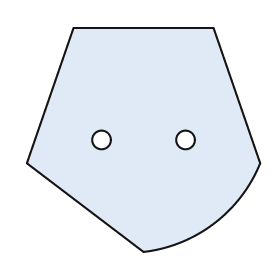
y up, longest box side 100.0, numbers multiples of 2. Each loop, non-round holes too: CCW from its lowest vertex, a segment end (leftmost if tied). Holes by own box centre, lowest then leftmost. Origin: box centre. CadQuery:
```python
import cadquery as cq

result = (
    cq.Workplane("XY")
    .moveTo(0.0, -48.0)
    .threePointArc((30.0, -36.0), (50.0, -10.0))
    .lineTo(30.0, 48.0)
    .lineTo(-30.0, 48.0)
    .lineTo(-50.0, -10.0)
    .close()
    .moveTo(-18.0, 0.0)
    .circle(4.0)
    .moveTo(18.0, 0.0)
    .circle(4.0)
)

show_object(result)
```